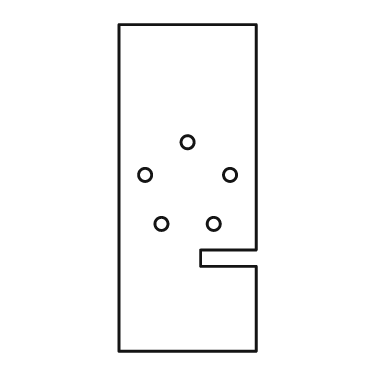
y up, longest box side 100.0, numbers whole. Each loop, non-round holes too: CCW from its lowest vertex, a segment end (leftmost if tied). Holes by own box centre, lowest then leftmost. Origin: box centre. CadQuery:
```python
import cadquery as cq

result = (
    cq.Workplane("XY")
    .moveTo(-21.0, -50.0)
    .lineTo(21.0, -50.0)
    .lineTo(21.0, -24.0)
    .lineTo(4.0, -24.0)
    .lineTo(4.0, -19.0)
    .lineTo(21.0, -19.0)
    .lineTo(21.0, 50.0)
    .lineTo(-21.0, 50.0)
    .close()
    .moveTo(-8.0, -11.0)
    .circle(2.0)
    .moveTo(8.0, -11.0)
    .circle(2.0)
    .moveTo(-13.0, 4.0)
    .circle(2.0)
    .moveTo(13.0, 4.0)
    .circle(2.0)
    .moveTo(0.0, 14.0)
    .circle(2.0)
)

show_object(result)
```